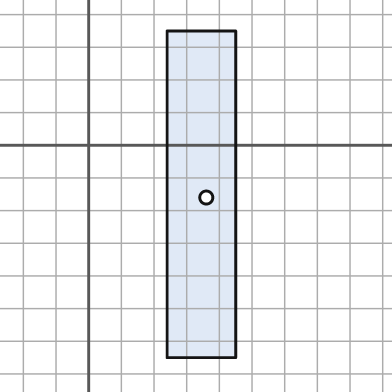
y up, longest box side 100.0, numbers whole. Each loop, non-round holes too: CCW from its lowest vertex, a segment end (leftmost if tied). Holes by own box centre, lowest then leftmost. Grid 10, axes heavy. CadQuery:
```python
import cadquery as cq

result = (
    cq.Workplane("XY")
    .moveTo(24.0, -65.0)
    .lineTo(45.0, -65.0)
    .lineTo(45.0, 35.0)
    .lineTo(24.0, 35.0)
    .close()
    .moveTo(36.0, -16.0)
    .circle(2.0)
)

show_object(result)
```